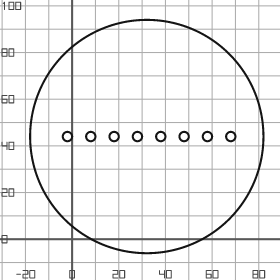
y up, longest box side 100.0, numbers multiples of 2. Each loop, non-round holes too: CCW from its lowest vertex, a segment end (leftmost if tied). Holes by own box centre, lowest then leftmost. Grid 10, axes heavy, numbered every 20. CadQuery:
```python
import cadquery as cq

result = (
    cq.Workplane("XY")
    .moveTo(32.0, 44.0)
    .circle(50.0)
    .moveTo(-2.0, 44.0)
    .circle(2.0)
    .moveTo(8.0, 44.0)
    .circle(2.0)
    .moveTo(18.0, 44.0)
    .circle(2.0)
    .moveTo(28.0, 44.0)
    .circle(2.0)
    .moveTo(38.0, 44.0)
    .circle(2.0)
    .moveTo(48.0, 44.0)
    .circle(2.0)
    .moveTo(58.0, 44.0)
    .circle(2.0)
    .moveTo(68.0, 44.0)
    .circle(2.0)
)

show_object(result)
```